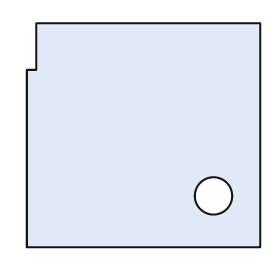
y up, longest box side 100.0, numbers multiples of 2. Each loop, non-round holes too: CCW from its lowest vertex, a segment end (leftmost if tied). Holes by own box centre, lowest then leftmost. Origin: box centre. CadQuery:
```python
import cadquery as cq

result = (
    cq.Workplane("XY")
    .moveTo(-50.0, -48.0)
    .lineTo(50.0, -48.0)
    .lineTo(50.0, 48.0)
    .lineTo(-46.0, 48.0)
    .lineTo(-46.0, 28.0)
    .lineTo(-50.0, 28.0)
    .close()
    .moveTo(30.0, -26.0)
    .circle(8.0)
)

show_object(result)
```